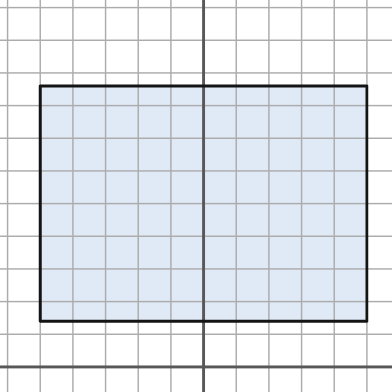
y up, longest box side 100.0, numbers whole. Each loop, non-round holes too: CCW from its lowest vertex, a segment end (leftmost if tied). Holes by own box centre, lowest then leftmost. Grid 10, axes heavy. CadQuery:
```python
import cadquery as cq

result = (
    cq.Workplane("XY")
    .moveTo(-50.0, 14.0)
    .lineTo(50.0, 14.0)
    .lineTo(50.0, 86.0)
    .lineTo(-50.0, 86.0)
    .close()
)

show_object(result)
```